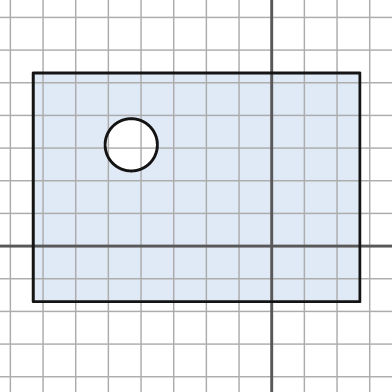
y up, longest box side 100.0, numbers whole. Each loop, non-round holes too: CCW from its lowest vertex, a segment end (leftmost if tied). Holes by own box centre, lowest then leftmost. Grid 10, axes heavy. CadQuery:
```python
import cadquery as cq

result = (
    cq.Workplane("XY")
    .moveTo(-73.0, -17.0)
    .lineTo(27.0, -17.0)
    .lineTo(27.0, 53.0)
    .lineTo(-73.0, 53.0)
    .close()
    .moveTo(-43.0, 31.0)
    .circle(8.0)
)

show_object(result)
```